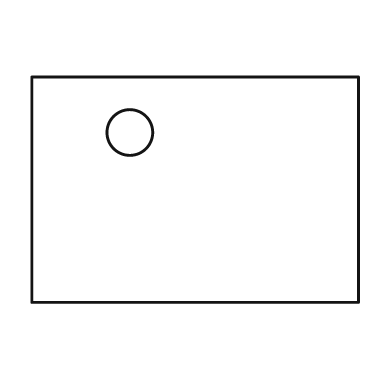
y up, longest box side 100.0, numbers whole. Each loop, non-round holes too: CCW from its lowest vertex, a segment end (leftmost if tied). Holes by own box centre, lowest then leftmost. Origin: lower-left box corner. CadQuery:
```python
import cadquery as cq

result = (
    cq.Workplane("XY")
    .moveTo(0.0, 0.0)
    .lineTo(100.0, 0.0)
    .lineTo(100.0, 69.0)
    .lineTo(0.0, 69.0)
    .close()
    .moveTo(30.0, 52.0)
    .circle(7.0)
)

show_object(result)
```